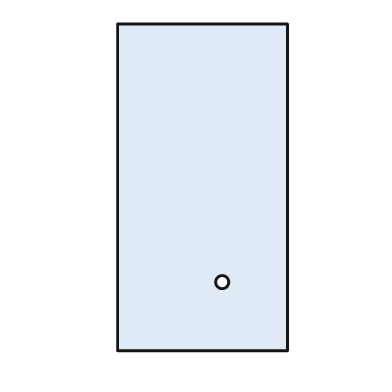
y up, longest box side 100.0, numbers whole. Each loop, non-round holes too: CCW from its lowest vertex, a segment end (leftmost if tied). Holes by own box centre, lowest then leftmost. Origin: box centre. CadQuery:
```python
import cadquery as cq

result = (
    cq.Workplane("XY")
    .moveTo(-26.0, -50.0)
    .lineTo(26.0, -50.0)
    .lineTo(26.0, 50.0)
    .lineTo(-26.0, 50.0)
    .close()
    .moveTo(6.0, -29.0)
    .circle(2.0)
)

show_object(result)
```